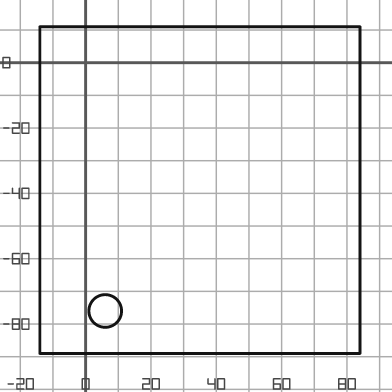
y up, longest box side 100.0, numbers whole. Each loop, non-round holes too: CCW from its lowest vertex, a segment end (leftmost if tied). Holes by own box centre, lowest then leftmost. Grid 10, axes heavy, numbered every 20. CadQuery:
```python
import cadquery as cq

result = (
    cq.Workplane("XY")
    .moveTo(-14.0, -89.0)
    .lineTo(84.0, -89.0)
    .lineTo(84.0, 11.0)
    .lineTo(-14.0, 11.0)
    .close()
    .moveTo(6.0, -76.0)
    .circle(5.0)
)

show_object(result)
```